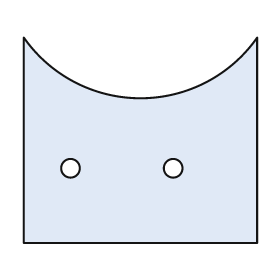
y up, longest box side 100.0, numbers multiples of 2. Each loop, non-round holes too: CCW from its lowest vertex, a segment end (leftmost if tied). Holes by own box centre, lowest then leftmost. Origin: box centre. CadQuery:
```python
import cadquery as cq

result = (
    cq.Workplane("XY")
    .moveTo(-50.0, -44.0)
    .lineTo(50.0, -44.0)
    .lineTo(50.0, 44.0)
    .threePointArc((0.0, 18.0), (-50.0, 44.0))
    .close()
    .moveTo(-30.0, -12.0)
    .circle(4.0)
    .moveTo(14.0, -12.0)
    .circle(4.0)
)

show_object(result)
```